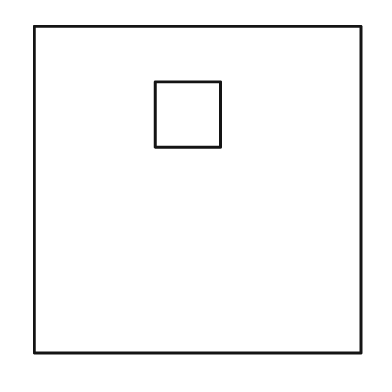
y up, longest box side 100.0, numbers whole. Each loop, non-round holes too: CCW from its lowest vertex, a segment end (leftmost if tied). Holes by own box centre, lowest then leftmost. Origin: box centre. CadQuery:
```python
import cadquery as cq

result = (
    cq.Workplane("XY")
    .moveTo(-50.0, -50.0)
    .lineTo(50.0, -50.0)
    .lineTo(50.0, 50.0)
    .lineTo(-50.0, 50.0)
    .close()
    .moveTo(-13.0, 13.0)
    .lineTo(7.0, 13.0)
    .lineTo(7.0, 33.0)
    .lineTo(-13.0, 33.0)
    .close()
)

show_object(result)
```